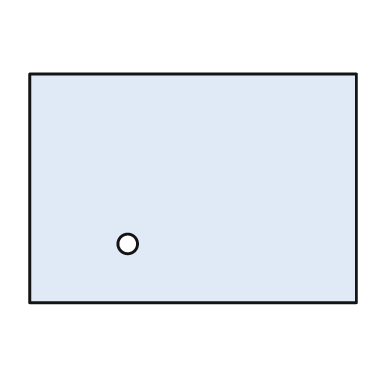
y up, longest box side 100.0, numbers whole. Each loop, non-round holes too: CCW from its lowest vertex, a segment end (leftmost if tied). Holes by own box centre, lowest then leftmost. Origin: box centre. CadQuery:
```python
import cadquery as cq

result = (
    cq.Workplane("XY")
    .moveTo(-50.0, -35.0)
    .lineTo(50.0, -35.0)
    .lineTo(50.0, 35.0)
    .lineTo(-50.0, 35.0)
    .close()
    .moveTo(-20.0, -17.0)
    .circle(3.0)
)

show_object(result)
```